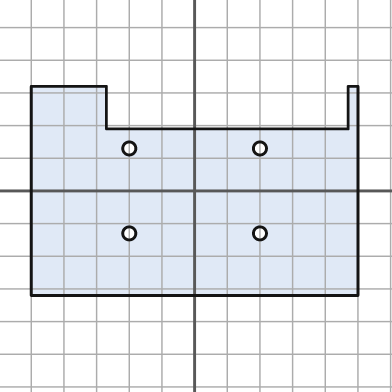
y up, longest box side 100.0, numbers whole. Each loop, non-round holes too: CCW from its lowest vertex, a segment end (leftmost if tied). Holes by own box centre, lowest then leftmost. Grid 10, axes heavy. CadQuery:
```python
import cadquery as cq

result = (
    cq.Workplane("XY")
    .moveTo(-50.0, -32.0)
    .lineTo(50.0, -32.0)
    .lineTo(50.0, 32.0)
    .lineTo(47.0, 32.0)
    .lineTo(47.0, 19.0)
    .lineTo(-27.0, 19.0)
    .lineTo(-27.0, 32.0)
    .lineTo(-50.0, 32.0)
    .close()
    .moveTo(-20.0, -13.0)
    .circle(2.0)
    .moveTo(20.0, -13.0)
    .circle(2.0)
    .moveTo(-20.0, 13.0)
    .circle(2.0)
    .moveTo(20.0, 13.0)
    .circle(2.0)
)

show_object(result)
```